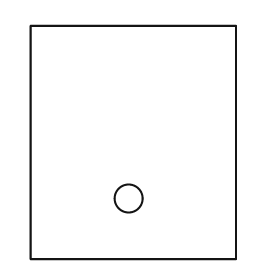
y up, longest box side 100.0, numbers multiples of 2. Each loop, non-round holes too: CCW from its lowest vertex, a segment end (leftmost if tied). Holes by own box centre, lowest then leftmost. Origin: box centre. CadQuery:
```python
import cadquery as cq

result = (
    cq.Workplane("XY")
    .moveTo(-44.0, -50.0)
    .lineTo(44.0, -50.0)
    .lineTo(44.0, 50.0)
    .lineTo(-44.0, 50.0)
    .close()
    .moveTo(-2.0, -24.0)
    .circle(6.0)
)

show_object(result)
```